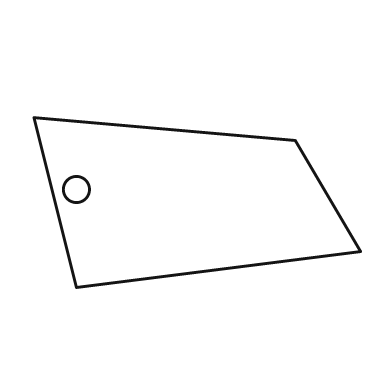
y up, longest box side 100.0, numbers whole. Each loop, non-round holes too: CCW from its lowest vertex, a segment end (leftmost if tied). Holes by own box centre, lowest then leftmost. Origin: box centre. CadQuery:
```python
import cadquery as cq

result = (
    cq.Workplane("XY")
    .moveTo(-37.0, -26.0)
    .lineTo(50.0, -15.0)
    .lineTo(30.0, 19.0)
    .lineTo(-50.0, 26.0)
    .close()
    .moveTo(-37.0, 4.0)
    .circle(4.0)
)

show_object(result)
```